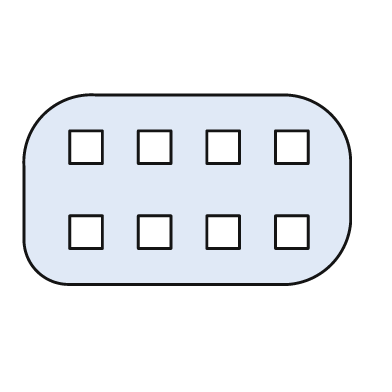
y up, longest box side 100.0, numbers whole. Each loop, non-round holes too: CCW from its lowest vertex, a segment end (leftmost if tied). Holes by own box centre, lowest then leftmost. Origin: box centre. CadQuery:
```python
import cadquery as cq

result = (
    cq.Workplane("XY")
    .moveTo(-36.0, -29.0)
    .lineTo(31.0, -29.0)
    .threePointArc((44.0, -23.0), (50.0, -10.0))
    .lineTo(50.0, 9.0)
    .threePointArc((44.0, 23.0), (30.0, 29.0))
    .lineTo(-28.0, 29.0)
    .threePointArc((-44.0, 23.0), (-50.0, 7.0))
    .lineTo(-50.0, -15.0)
    .threePointArc((-46.0, -25.0), (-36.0, -29.0))
    .close()
    .moveTo(-36.0, -18.0)
    .lineTo(-26.0, -18.0)
    .lineTo(-26.0, -8.0)
    .lineTo(-36.0, -8.0)
    .close()
    .moveTo(-15.0, -18.0)
    .lineTo(-5.0, -18.0)
    .lineTo(-5.0, -8.0)
    .lineTo(-15.0, -8.0)
    .close()
    .moveTo(6.0, -18.0)
    .lineTo(16.0, -18.0)
    .lineTo(16.0, -8.0)
    .lineTo(6.0, -8.0)
    .close()
    .moveTo(27.0, -18.0)
    .lineTo(37.0, -18.0)
    .lineTo(37.0, -8.0)
    .lineTo(27.0, -8.0)
    .close()
    .moveTo(-36.0, 8.0)
    .lineTo(-26.0, 8.0)
    .lineTo(-26.0, 18.0)
    .lineTo(-36.0, 18.0)
    .close()
    .moveTo(-15.0, 8.0)
    .lineTo(-5.0, 8.0)
    .lineTo(-5.0, 18.0)
    .lineTo(-15.0, 18.0)
    .close()
    .moveTo(6.0, 8.0)
    .lineTo(16.0, 8.0)
    .lineTo(16.0, 18.0)
    .lineTo(6.0, 18.0)
    .close()
    .moveTo(27.0, 8.0)
    .lineTo(37.0, 8.0)
    .lineTo(37.0, 18.0)
    .lineTo(27.0, 18.0)
    .close()
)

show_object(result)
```